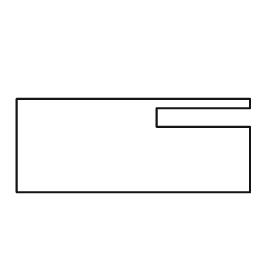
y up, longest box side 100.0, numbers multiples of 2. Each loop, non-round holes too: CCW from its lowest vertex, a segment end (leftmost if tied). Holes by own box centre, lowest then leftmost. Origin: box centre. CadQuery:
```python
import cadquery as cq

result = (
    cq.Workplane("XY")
    .moveTo(-50.0, -20.0)
    .lineTo(50.0, -20.0)
    .lineTo(50.0, 8.0)
    .lineTo(10.0, 8.0)
    .lineTo(10.0, 16.0)
    .lineTo(50.0, 16.0)
    .lineTo(50.0, 20.0)
    .lineTo(-50.0, 20.0)
    .close()
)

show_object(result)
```